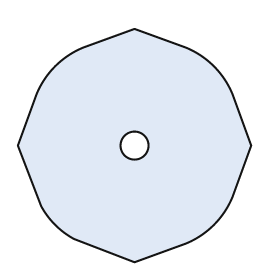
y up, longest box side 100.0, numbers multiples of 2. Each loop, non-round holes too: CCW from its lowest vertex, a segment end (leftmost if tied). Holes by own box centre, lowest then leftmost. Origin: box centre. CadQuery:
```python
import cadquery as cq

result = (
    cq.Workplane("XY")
    .moveTo(0.0, -50.0)
    .lineTo(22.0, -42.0)
    .threePointArc((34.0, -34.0), (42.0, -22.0))
    .lineTo(50.0, 0.0)
    .lineTo(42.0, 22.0)
    .threePointArc((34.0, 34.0), (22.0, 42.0))
    .lineTo(0.0, 50.0)
    .lineTo(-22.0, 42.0)
    .threePointArc((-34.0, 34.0), (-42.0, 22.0))
    .lineTo(-50.0, 0.0)
    .lineTo(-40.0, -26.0)
    .threePointArc((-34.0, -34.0), (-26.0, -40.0))
    .close()
    .moveTo(0.0, 0.0)
    .circle(6.0)
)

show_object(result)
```